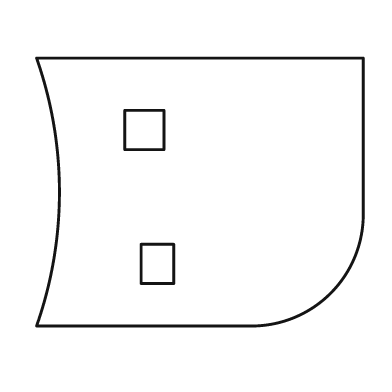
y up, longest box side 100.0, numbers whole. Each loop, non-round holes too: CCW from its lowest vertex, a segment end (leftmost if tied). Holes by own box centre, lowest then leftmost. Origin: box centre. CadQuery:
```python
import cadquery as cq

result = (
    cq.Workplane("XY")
    .moveTo(-50.0, -41.0)
    .lineTo(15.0, -41.0)
    .threePointArc((40.0, -31.0), (50.0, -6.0))
    .lineTo(50.0, 41.0)
    .lineTo(-50.0, 41.0)
    .threePointArc((-43.0, 0.0), (-50.0, -41.0))
    .close()
    .moveTo(-18.0, -28.0)
    .lineTo(-8.0, -28.0)
    .lineTo(-8.0, -16.0)
    .lineTo(-18.0, -16.0)
    .close()
    .moveTo(-23.0, 13.0)
    .lineTo(-11.0, 13.0)
    .lineTo(-11.0, 25.0)
    .lineTo(-23.0, 25.0)
    .close()
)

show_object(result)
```